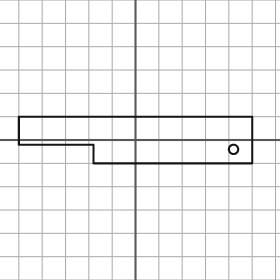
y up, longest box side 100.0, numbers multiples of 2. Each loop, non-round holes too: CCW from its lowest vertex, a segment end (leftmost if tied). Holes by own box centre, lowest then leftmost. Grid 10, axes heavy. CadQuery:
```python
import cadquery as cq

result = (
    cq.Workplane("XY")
    .moveTo(-18.0, -10.0)
    .lineTo(50.0, -10.0)
    .lineTo(50.0, 10.0)
    .lineTo(-50.0, 10.0)
    .lineTo(-50.0, -2.0)
    .lineTo(-18.0, -2.0)
    .close()
    .moveTo(42.0, -4.0)
    .circle(2.0)
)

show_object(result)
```